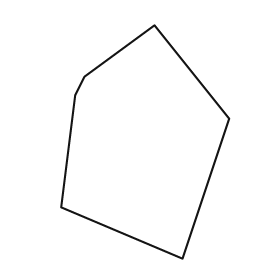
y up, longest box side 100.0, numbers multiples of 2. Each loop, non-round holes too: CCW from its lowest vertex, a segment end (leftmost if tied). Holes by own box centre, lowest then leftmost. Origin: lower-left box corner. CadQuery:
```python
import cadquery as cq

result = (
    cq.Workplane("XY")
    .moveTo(52.0, 0.0)
    .lineTo(72.0, 60.0)
    .lineTo(40.0, 100.0)
    .lineTo(10.0, 78.0)
    .lineTo(6.0, 70.0)
    .lineTo(0.0, 22.0)
    .close()
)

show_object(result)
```